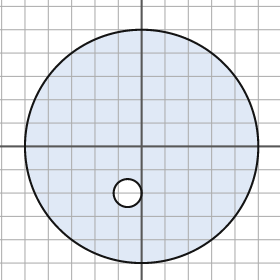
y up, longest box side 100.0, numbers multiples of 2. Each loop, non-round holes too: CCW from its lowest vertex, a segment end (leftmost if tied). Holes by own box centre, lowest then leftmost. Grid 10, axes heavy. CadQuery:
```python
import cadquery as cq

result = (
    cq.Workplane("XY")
    .moveTo(0.0, 0.0)
    .circle(50.0)
    .moveTo(-6.0, -20.0)
    .circle(6.0)
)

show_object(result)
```